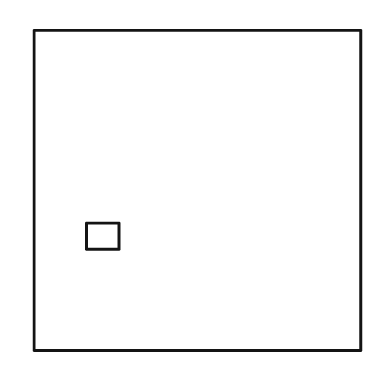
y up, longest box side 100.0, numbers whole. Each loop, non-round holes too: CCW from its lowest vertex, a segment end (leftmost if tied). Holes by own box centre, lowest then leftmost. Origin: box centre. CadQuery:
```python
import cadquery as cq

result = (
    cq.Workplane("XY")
    .moveTo(-50.0, -49.0)
    .lineTo(50.0, -49.0)
    .lineTo(50.0, 49.0)
    .lineTo(-50.0, 49.0)
    .close()
    .moveTo(-34.0, -18.0)
    .lineTo(-24.0, -18.0)
    .lineTo(-24.0, -10.0)
    .lineTo(-34.0, -10.0)
    .close()
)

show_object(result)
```